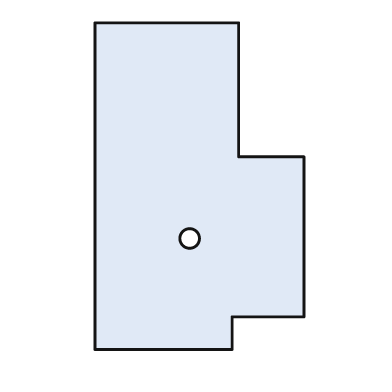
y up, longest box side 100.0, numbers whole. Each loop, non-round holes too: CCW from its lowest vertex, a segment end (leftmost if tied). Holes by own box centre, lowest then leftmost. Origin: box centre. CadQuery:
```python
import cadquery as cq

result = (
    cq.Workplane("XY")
    .moveTo(-32.0, -50.0)
    .lineTo(10.0, -50.0)
    .lineTo(10.0, -40.0)
    .lineTo(32.0, -40.0)
    .lineTo(32.0, 9.0)
    .lineTo(12.0, 9.0)
    .lineTo(12.0, 50.0)
    .lineTo(-32.0, 50.0)
    .close()
    .moveTo(-3.0, -16.0)
    .circle(3.0)
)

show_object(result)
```